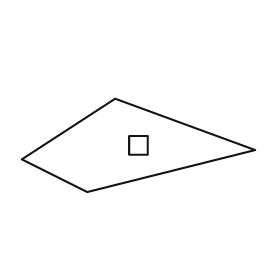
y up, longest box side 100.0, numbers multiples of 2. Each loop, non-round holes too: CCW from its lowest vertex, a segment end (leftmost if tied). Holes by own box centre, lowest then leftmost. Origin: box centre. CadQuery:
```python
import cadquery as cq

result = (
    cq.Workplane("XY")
    .moveTo(-22.0, -20.0)
    .lineTo(50.0, -2.0)
    .lineTo(-10.0, 20.0)
    .lineTo(-50.0, -6.0)
    .close()
    .moveTo(-4.0, -4.0)
    .lineTo(4.0, -4.0)
    .lineTo(4.0, 4.0)
    .lineTo(-4.0, 4.0)
    .close()
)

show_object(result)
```